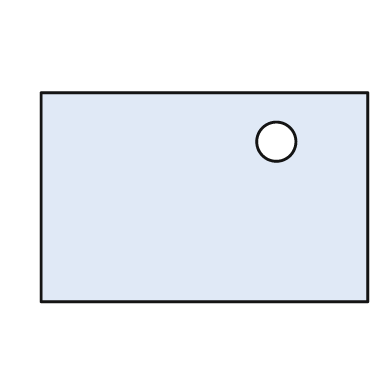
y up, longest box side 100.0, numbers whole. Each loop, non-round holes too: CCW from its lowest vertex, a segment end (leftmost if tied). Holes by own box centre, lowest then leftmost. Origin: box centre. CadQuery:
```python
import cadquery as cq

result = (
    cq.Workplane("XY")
    .moveTo(-50.0, -32.0)
    .lineTo(50.0, -32.0)
    .lineTo(50.0, 32.0)
    .lineTo(-50.0, 32.0)
    .close()
    .moveTo(22.0, 17.0)
    .circle(6.0)
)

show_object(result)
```